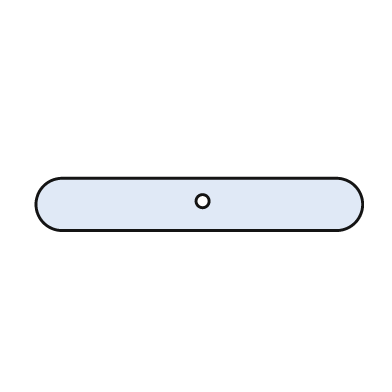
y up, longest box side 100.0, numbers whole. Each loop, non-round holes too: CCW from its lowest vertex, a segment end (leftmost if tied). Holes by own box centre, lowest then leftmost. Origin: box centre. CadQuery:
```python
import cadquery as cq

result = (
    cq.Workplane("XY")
    .moveTo(-42.0, -8.0)
    .lineTo(42.0, -8.0)
    .threePointArc((50.0, 0.0), (42.0, 8.0))
    .lineTo(-42.0, 8.0)
    .threePointArc((-50.0, 0.0), (-42.0, -8.0))
    .close()
    .moveTo(1.0, 1.0)
    .circle(2.0)
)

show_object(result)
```